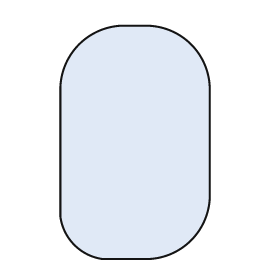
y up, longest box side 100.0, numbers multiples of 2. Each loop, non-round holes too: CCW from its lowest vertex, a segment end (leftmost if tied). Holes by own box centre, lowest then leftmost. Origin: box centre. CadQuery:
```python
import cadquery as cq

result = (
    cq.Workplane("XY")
    .moveTo(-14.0, -50.0)
    .lineTo(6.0, -50.0)
    .threePointArc((24.0, -42.0), (32.0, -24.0))
    .lineTo(32.0, 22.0)
    .threePointArc((24.0, 42.0), (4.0, 50.0))
    .lineTo(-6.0, 50.0)
    .threePointArc((-24.0, 42.0), (-32.0, 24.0))
    .lineTo(-32.0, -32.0)
    .threePointArc((-26.0, -44.0), (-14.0, -50.0))
    .close()
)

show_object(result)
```